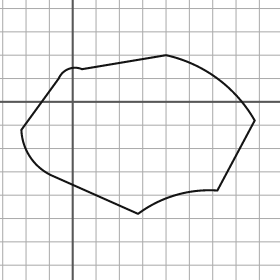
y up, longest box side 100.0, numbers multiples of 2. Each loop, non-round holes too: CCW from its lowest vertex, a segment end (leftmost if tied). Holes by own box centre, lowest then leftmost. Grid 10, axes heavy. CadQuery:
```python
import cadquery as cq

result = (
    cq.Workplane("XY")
    .moveTo(28.0, -48.0)
    .threePointArc((44.0, -40.0), (62.0, -38.0))
    .lineTo(78.0, -8.0)
    .threePointArc((62.0, 10.0), (40.0, 20.0))
    .lineTo(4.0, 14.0)
    .threePointArc((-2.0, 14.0), (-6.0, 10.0))
    .lineTo(-22.0, -12.0)
    .threePointArc((-18.0, -24.0), (-8.0, -32.0))
    .close()
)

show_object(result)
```